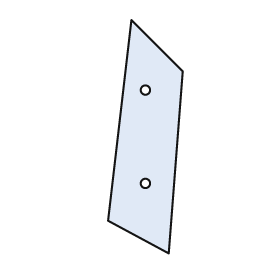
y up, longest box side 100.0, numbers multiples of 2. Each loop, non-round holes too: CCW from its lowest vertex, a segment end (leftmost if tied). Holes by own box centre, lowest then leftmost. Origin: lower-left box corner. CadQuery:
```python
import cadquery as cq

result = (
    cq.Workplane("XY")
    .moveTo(26.0, 0.0)
    .lineTo(32.0, 78.0)
    .lineTo(10.0, 100.0)
    .lineTo(0.0, 14.0)
    .close()
    .moveTo(16.0, 30.0)
    .circle(2.0)
    .moveTo(16.0, 70.0)
    .circle(2.0)
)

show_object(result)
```